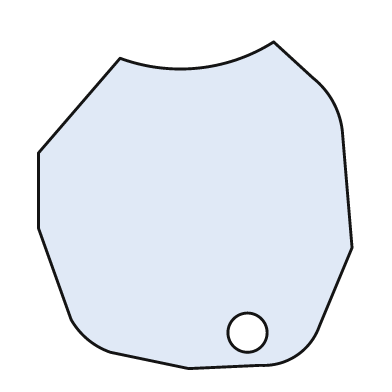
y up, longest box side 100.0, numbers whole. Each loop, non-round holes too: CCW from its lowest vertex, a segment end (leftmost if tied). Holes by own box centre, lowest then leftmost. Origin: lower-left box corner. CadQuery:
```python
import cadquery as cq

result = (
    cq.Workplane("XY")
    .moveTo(46.0, 0.0)
    .lineTo(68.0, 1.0)
    .threePointArc((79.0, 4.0), (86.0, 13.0))
    .lineTo(96.0, 37.0)
    .lineTo(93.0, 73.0)
    .threePointArc((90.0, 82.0), (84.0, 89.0))
    .lineTo(72.0, 100.0)
    .threePointArc((49.0, 92.0), (25.0, 95.0))
    .lineTo(0.0, 66.0)
    .lineTo(0.0, 43.0)
    .lineTo(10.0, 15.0)
    .threePointArc((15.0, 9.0), (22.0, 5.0))
    .close()
    .moveTo(64.0, 11.0)
    .circle(6.0)
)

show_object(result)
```